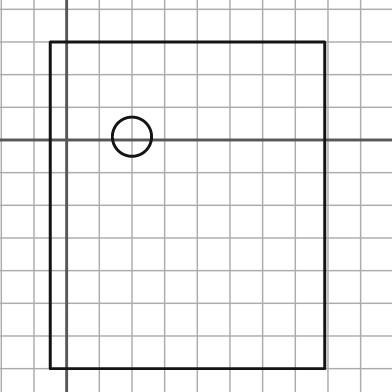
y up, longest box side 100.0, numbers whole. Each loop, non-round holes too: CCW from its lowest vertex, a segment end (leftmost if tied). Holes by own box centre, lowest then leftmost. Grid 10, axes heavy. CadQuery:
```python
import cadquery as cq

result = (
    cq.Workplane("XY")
    .moveTo(-5.0, -70.0)
    .lineTo(79.0, -70.0)
    .lineTo(79.0, 30.0)
    .lineTo(-5.0, 30.0)
    .close()
    .moveTo(20.0, 1.0)
    .circle(6.0)
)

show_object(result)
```